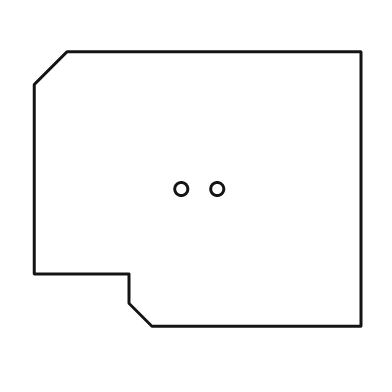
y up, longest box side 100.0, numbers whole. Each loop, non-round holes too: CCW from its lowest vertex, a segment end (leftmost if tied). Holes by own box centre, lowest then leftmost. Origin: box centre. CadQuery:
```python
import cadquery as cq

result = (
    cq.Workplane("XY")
    .moveTo(-14.0, -42.0)
    .lineTo(50.0, -42.0)
    .lineTo(50.0, 42.0)
    .lineTo(-40.0, 42.0)
    .lineTo(-50.0, 32.0)
    .lineTo(-50.0, -26.0)
    .lineTo(-21.0, -26.0)
    .lineTo(-21.0, -35.0)
    .close()
    .moveTo(-5.0, 0.0)
    .circle(2.0)
    .moveTo(6.0, 0.0)
    .circle(2.0)
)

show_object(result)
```